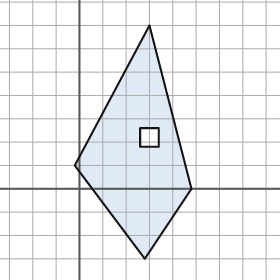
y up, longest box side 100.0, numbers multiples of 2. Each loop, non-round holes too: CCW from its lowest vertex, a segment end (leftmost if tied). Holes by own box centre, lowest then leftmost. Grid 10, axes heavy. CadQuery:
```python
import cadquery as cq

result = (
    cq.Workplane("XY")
    .moveTo(28.0, -30.0)
    .lineTo(48.0, 0.0)
    .lineTo(30.0, 70.0)
    .lineTo(-2.0, 10.0)
    .close()
    .moveTo(26.0, 18.0)
    .lineTo(34.0, 18.0)
    .lineTo(34.0, 26.0)
    .lineTo(26.0, 26.0)
    .close()
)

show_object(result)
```